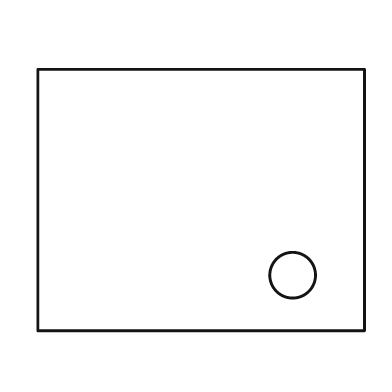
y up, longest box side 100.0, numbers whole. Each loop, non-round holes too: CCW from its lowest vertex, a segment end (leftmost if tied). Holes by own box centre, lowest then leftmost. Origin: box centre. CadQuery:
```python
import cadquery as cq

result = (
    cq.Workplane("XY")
    .moveTo(-50.0, -40.0)
    .lineTo(50.0, -40.0)
    .lineTo(50.0, 40.0)
    .lineTo(-50.0, 40.0)
    .close()
    .moveTo(28.0, -23.0)
    .circle(7.0)
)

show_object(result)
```